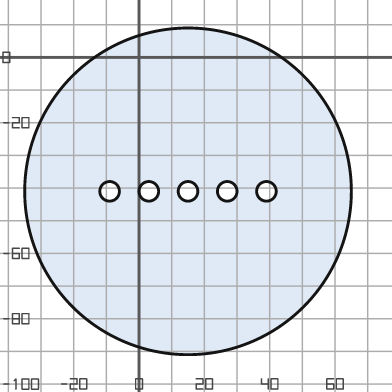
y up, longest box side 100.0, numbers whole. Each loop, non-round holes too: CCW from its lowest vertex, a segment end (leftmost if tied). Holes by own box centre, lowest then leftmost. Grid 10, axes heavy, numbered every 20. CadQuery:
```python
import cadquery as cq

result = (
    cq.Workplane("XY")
    .moveTo(15.0, -41.0)
    .circle(50.0)
    .moveTo(-9.0, -41.0)
    .circle(3.0)
    .moveTo(3.0, -41.0)
    .circle(3.0)
    .moveTo(15.0, -41.0)
    .circle(3.0)
    .moveTo(27.0, -41.0)
    .circle(3.0)
    .moveTo(39.0, -41.0)
    .circle(3.0)
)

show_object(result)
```